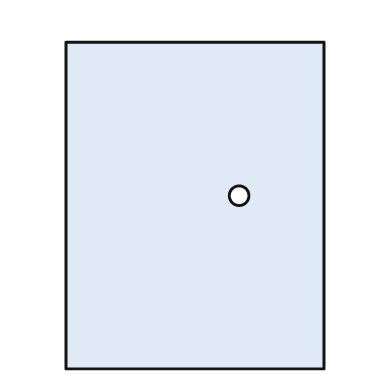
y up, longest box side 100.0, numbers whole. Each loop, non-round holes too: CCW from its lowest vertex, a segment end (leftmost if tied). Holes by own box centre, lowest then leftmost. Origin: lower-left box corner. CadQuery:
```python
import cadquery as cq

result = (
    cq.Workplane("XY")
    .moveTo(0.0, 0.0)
    .lineTo(79.0, 0.0)
    .lineTo(79.0, 100.0)
    .lineTo(0.0, 100.0)
    .close()
    .moveTo(53.0, 53.0)
    .circle(3.0)
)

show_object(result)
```